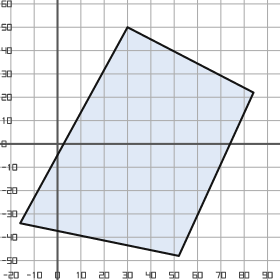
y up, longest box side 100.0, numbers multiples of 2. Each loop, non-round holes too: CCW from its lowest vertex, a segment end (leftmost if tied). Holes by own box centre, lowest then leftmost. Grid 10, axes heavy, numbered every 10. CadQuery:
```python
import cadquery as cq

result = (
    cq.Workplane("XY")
    .moveTo(52.0, -48.0)
    .lineTo(84.0, 22.0)
    .lineTo(30.0, 50.0)
    .lineTo(-16.0, -34.0)
    .close()
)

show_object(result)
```